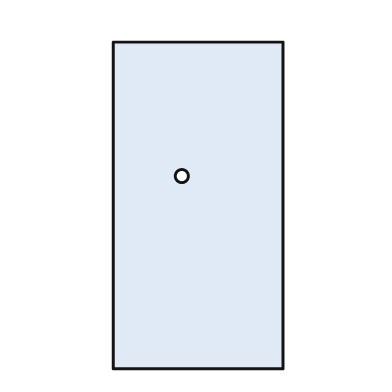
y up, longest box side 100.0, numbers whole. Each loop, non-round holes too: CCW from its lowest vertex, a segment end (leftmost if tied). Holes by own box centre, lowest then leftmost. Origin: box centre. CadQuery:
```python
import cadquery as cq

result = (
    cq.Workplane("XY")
    .moveTo(-26.0, -50.0)
    .lineTo(26.0, -50.0)
    .lineTo(26.0, 50.0)
    .lineTo(-26.0, 50.0)
    .close()
    .moveTo(-5.0, 9.0)
    .circle(2.0)
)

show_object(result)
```